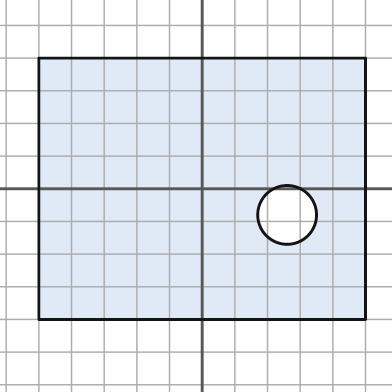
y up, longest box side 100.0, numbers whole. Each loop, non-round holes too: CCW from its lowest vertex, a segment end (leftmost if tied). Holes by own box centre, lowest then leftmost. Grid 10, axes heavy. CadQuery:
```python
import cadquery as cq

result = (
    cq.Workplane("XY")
    .moveTo(-50.0, -40.0)
    .lineTo(50.0, -40.0)
    .lineTo(50.0, 40.0)
    .lineTo(-50.0, 40.0)
    .close()
    .moveTo(26.0, -8.0)
    .circle(9.0)
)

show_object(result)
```